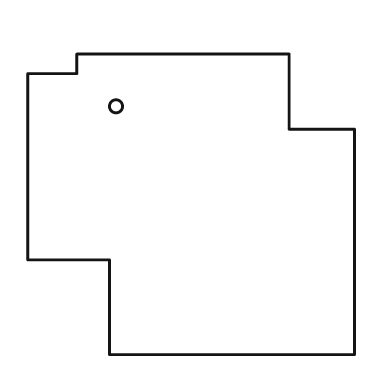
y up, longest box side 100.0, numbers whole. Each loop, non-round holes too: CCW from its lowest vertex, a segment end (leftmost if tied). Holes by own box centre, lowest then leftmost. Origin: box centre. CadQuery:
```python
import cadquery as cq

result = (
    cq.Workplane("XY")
    .moveTo(-25.0, -46.0)
    .lineTo(50.0, -46.0)
    .lineTo(50.0, 23.0)
    .lineTo(30.0, 23.0)
    .lineTo(30.0, 46.0)
    .lineTo(-35.0, 46.0)
    .lineTo(-35.0, 40.0)
    .lineTo(-50.0, 40.0)
    .lineTo(-50.0, -17.0)
    .lineTo(-25.0, -17.0)
    .close()
    .moveTo(-23.0, 30.0)
    .circle(2.0)
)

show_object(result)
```